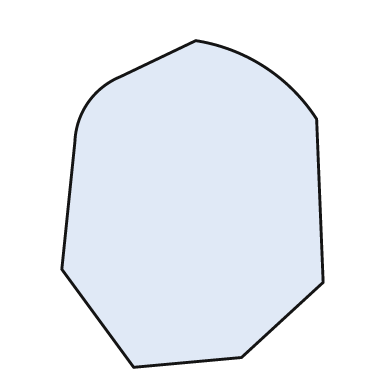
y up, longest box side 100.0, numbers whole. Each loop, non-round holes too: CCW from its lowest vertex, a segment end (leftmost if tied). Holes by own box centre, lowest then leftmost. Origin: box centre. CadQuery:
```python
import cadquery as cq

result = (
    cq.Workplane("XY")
    .moveTo(-18.0, -50.0)
    .lineTo(15.0, -47.0)
    .lineTo(40.0, -24.0)
    .lineTo(38.0, 26.0)
    .threePointArc((22.0, 42.0), (1.0, 50.0))
    .lineTo(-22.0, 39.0)
    .threePointArc((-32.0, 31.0), (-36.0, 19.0))
    .lineTo(-40.0, -20.0)
    .close()
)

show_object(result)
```